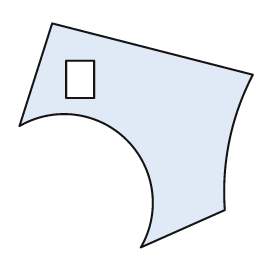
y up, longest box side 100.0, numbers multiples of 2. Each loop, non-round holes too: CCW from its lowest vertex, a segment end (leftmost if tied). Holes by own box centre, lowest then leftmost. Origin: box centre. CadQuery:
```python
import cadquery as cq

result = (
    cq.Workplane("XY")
    .moveTo(2.0, -48.0)
    .lineTo(38.0, -32.0)
    .threePointArc((40.0, -2.0), (50.0, 26.0))
    .lineTo(-36.0, 48.0)
    .lineTo(-50.0, 4.0)
    .threePointArc((-4.0, -2.0), (2.0, -48.0))
    .close()
    .moveTo(-30.0, 16.0)
    .lineTo(-18.0, 16.0)
    .lineTo(-18.0, 32.0)
    .lineTo(-30.0, 32.0)
    .close()
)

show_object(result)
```